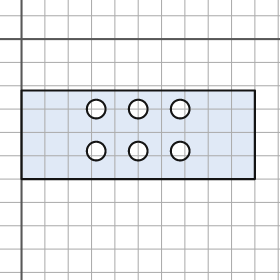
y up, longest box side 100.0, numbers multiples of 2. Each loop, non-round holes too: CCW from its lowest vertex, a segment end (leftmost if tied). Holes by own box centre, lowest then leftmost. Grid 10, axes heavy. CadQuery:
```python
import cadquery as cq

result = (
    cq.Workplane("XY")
    .moveTo(0.0, -60.0)
    .lineTo(100.0, -60.0)
    .lineTo(100.0, -22.0)
    .lineTo(0.0, -22.0)
    .close()
    .moveTo(32.0, -48.0)
    .circle(4.0)
    .moveTo(50.0, -48.0)
    .circle(4.0)
    .moveTo(68.0, -48.0)
    .circle(4.0)
    .moveTo(32.0, -30.0)
    .circle(4.0)
    .moveTo(50.0, -30.0)
    .circle(4.0)
    .moveTo(68.0, -30.0)
    .circle(4.0)
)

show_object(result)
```